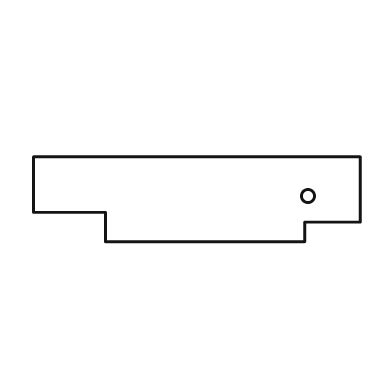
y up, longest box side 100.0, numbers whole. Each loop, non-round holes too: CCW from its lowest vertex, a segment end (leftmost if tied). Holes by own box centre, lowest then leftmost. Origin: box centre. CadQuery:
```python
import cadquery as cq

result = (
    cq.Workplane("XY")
    .moveTo(-28.0, -13.0)
    .lineTo(33.0, -13.0)
    .lineTo(33.0, -7.0)
    .lineTo(50.0, -7.0)
    .lineTo(50.0, 13.0)
    .lineTo(-50.0, 13.0)
    .lineTo(-50.0, -4.0)
    .lineTo(-28.0, -4.0)
    .close()
    .moveTo(34.0, 1.0)
    .circle(2.0)
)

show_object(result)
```